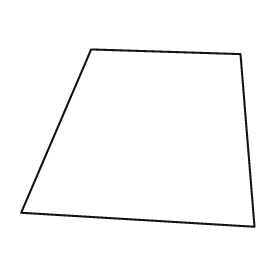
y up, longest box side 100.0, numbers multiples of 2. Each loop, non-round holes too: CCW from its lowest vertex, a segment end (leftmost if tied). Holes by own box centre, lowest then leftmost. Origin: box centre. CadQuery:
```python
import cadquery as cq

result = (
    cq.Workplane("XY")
    .moveTo(50.0, -38.0)
    .lineTo(44.0, 36.0)
    .lineTo(-20.0, 38.0)
    .lineTo(-50.0, -32.0)
    .close()
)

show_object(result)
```